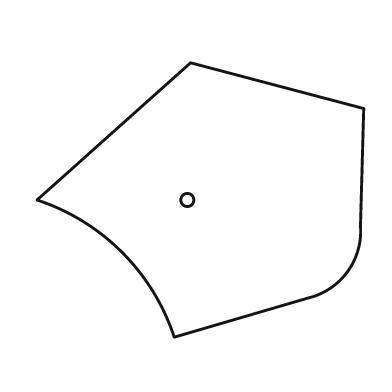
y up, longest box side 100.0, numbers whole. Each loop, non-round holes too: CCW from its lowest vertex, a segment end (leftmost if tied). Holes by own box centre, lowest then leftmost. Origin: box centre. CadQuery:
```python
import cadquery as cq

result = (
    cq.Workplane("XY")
    .moveTo(-8.0, -42.0)
    .lineTo(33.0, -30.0)
    .threePointArc((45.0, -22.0), (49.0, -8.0))
    .lineTo(50.0, 28.0)
    .lineTo(-3.0, 42.0)
    .lineTo(-50.0, 0.0)
    .threePointArc((-24.0, -16.0), (-8.0, -42.0))
    .close()
    .moveTo(-4.0, 0.0)
    .circle(2.0)
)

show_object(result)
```